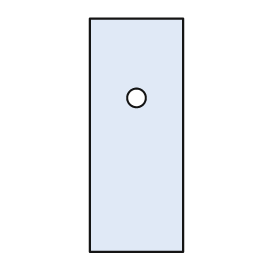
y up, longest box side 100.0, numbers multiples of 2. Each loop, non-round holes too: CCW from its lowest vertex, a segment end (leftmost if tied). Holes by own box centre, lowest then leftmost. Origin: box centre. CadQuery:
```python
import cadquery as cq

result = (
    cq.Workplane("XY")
    .moveTo(-20.0, -50.0)
    .lineTo(20.0, -50.0)
    .lineTo(20.0, 50.0)
    .lineTo(-20.0, 50.0)
    .close()
    .moveTo(0.0, 16.0)
    .circle(4.0)
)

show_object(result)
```